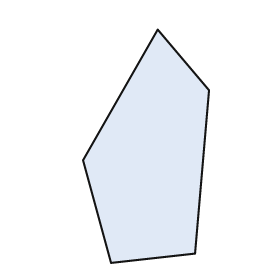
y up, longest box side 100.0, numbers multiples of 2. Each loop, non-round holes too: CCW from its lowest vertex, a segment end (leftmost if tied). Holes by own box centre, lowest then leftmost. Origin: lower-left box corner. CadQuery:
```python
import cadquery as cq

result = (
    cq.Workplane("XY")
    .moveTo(12.0, 0.0)
    .lineTo(48.0, 4.0)
    .lineTo(54.0, 74.0)
    .lineTo(32.0, 100.0)
    .lineTo(0.0, 44.0)
    .close()
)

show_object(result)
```